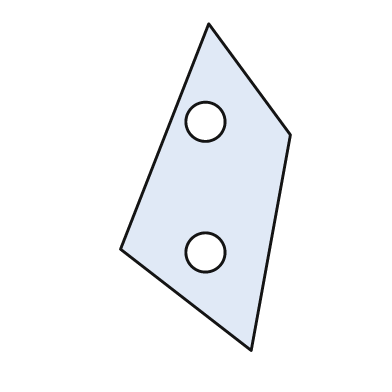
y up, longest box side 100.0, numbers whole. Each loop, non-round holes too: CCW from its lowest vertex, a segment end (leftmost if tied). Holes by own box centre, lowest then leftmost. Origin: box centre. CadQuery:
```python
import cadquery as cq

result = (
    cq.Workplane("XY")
    .moveTo(14.0, -50.0)
    .lineTo(26.0, 16.0)
    .lineTo(1.0, 50.0)
    .lineTo(-26.0, -19.0)
    .close()
    .moveTo(0.0, -20.0)
    .circle(6.0)
    .moveTo(0.0, 20.0)
    .circle(6.0)
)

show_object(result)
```